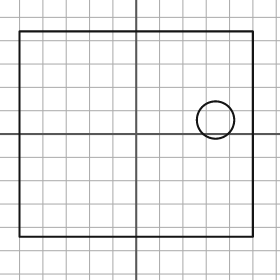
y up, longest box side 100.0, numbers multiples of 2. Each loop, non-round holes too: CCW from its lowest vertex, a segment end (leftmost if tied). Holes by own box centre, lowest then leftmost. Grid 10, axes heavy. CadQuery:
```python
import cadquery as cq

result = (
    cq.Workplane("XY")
    .moveTo(-50.0, -44.0)
    .lineTo(50.0, -44.0)
    .lineTo(50.0, 44.0)
    .lineTo(-50.0, 44.0)
    .close()
    .moveTo(34.0, 6.0)
    .circle(8.0)
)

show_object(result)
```